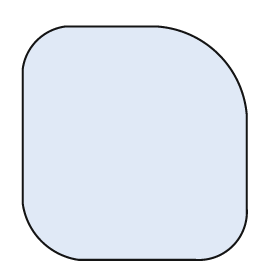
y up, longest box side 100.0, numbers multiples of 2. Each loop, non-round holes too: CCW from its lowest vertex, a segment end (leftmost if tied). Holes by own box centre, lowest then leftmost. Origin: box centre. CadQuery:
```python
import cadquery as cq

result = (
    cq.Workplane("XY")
    .moveTo(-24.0, -50.0)
    .lineTo(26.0, -50.0)
    .threePointArc((42.0, -44.0), (48.0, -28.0))
    .lineTo(48.0, 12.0)
    .threePointArc((36.0, 38.0), (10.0, 50.0))
    .lineTo(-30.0, 50.0)
    .threePointArc((-42.0, 44.0), (-48.0, 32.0))
    .lineTo(-48.0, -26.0)
    .threePointArc((-40.0, -42.0), (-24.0, -50.0))
    .close()
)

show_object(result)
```